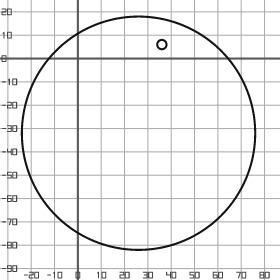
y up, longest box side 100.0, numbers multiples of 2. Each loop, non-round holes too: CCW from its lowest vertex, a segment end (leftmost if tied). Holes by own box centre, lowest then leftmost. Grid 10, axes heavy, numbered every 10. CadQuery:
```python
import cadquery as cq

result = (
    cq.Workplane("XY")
    .moveTo(26.0, -32.0)
    .circle(50.0)
    .moveTo(36.0, 6.0)
    .circle(2.0)
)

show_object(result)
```